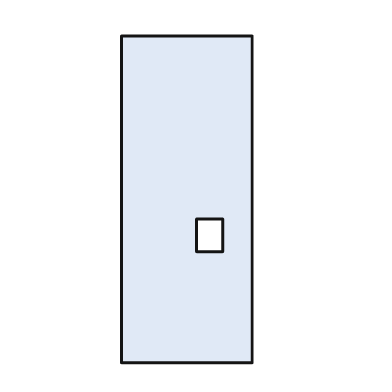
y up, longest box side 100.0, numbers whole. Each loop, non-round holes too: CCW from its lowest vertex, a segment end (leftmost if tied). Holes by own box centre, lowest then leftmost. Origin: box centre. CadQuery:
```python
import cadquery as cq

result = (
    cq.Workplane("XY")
    .moveTo(-20.0, -50.0)
    .lineTo(20.0, -50.0)
    .lineTo(20.0, 50.0)
    .lineTo(-20.0, 50.0)
    .close()
    .moveTo(3.0, -16.0)
    .lineTo(11.0, -16.0)
    .lineTo(11.0, -6.0)
    .lineTo(3.0, -6.0)
    .close()
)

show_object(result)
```